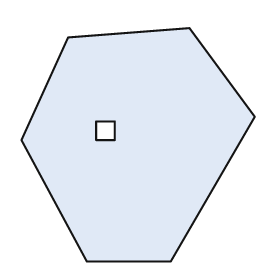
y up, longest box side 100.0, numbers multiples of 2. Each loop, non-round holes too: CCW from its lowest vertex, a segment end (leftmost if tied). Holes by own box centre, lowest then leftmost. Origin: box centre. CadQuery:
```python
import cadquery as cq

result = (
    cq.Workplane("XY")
    .moveTo(-22.0, -50.0)
    .lineTo(14.0, -50.0)
    .lineTo(50.0, 12.0)
    .lineTo(22.0, 50.0)
    .lineTo(-30.0, 46.0)
    .lineTo(-50.0, 2.0)
    .close()
    .moveTo(-18.0, 2.0)
    .lineTo(-10.0, 2.0)
    .lineTo(-10.0, 10.0)
    .lineTo(-18.0, 10.0)
    .close()
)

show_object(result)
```